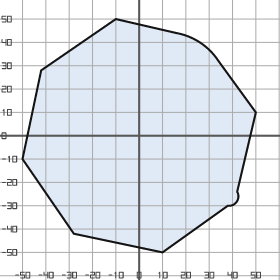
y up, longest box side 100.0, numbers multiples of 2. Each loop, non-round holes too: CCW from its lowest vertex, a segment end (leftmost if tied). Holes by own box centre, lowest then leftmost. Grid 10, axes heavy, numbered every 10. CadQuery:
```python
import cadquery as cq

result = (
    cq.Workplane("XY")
    .moveTo(10.0, -50.0)
    .lineTo(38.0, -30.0)
    .threePointArc((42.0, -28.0), (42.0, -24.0))
    .lineTo(50.0, 10.0)
    .lineTo(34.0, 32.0)
    .threePointArc((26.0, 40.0), (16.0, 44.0))
    .lineTo(-10.0, 50.0)
    .lineTo(-42.0, 28.0)
    .lineTo(-50.0, -10.0)
    .lineTo(-28.0, -42.0)
    .close()
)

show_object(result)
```